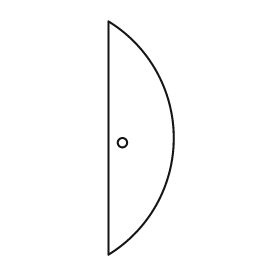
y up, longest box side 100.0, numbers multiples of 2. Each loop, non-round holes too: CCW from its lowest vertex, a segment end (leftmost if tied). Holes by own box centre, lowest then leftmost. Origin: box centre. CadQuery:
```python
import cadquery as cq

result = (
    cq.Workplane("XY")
    .moveTo(-14.0, -50.0)
    .threePointArc((14.0, 0.0), (-14.0, 50.0))
    .close()
    .moveTo(-8.0, -2.0)
    .circle(2.0)
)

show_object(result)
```